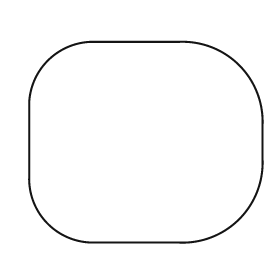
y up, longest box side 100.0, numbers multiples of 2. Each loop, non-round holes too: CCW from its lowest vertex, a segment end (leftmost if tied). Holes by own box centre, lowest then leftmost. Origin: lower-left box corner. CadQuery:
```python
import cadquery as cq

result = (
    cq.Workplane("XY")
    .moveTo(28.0, 0.0)
    .lineTo(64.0, 0.0)
    .threePointArc((90.0, 10.0), (100.0, 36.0))
    .lineTo(100.0, 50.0)
    .threePointArc((90.0, 76.0), (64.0, 86.0))
    .lineTo(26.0, 86.0)
    .threePointArc((8.0, 78.0), (0.0, 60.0))
    .lineTo(0.0, 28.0)
    .threePointArc((8.0, 8.0), (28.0, 0.0))
    .close()
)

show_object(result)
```